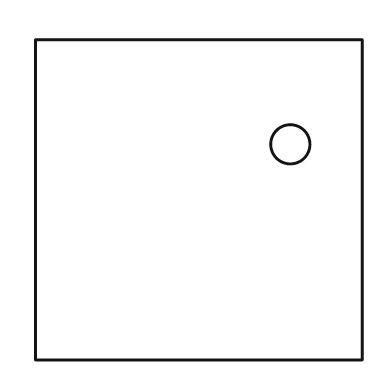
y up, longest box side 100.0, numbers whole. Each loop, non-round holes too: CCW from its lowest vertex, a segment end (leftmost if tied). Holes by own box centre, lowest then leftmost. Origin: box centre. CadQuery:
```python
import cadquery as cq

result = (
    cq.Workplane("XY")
    .moveTo(-50.0, -49.0)
    .lineTo(50.0, -49.0)
    .lineTo(50.0, 49.0)
    .lineTo(-50.0, 49.0)
    .close()
    .moveTo(28.0, 17.0)
    .circle(6.0)
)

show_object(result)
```